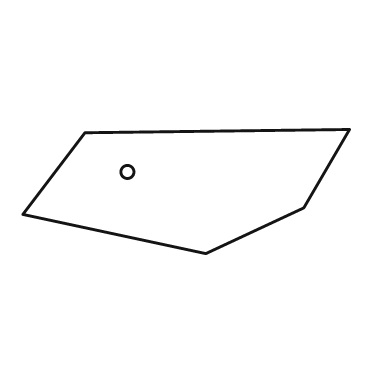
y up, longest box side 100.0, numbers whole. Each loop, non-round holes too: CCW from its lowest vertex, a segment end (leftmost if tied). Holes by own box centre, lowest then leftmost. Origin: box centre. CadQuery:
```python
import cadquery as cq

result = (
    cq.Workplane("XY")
    .moveTo(6.0, -19.0)
    .lineTo(36.0, -5.0)
    .lineTo(50.0, 19.0)
    .lineTo(-31.0, 18.0)
    .lineTo(-50.0, -7.0)
    .close()
    .moveTo(-18.0, 6.0)
    .circle(2.0)
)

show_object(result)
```